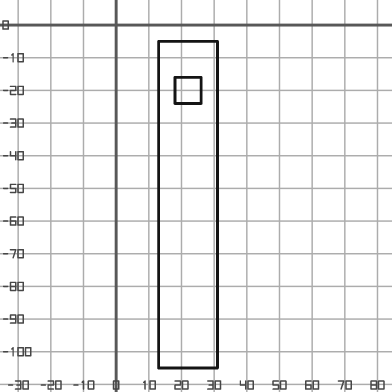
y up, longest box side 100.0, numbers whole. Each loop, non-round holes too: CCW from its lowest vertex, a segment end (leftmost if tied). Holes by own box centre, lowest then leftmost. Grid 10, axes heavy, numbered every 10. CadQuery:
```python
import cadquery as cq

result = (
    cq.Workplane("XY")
    .moveTo(13.0, -105.0)
    .lineTo(31.0, -105.0)
    .lineTo(31.0, -5.0)
    .lineTo(13.0, -5.0)
    .close()
    .moveTo(18.0, -24.0)
    .lineTo(26.0, -24.0)
    .lineTo(26.0, -16.0)
    .lineTo(18.0, -16.0)
    .close()
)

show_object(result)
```